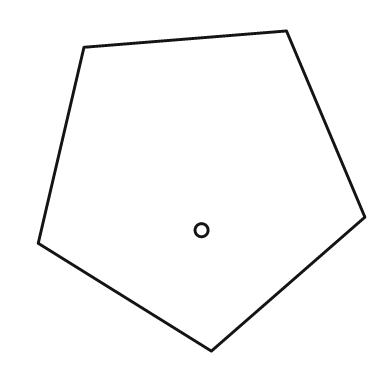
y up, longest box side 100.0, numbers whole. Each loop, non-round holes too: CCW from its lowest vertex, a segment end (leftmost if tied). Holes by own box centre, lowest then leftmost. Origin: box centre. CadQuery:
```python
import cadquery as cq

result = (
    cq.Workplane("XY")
    .moveTo(3.0, -49.0)
    .lineTo(50.0, -8.0)
    .lineTo(26.0, 49.0)
    .lineTo(-36.0, 44.0)
    .lineTo(-50.0, -16.0)
    .close()
    .moveTo(0.0, -12.0)
    .circle(2.0)
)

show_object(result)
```